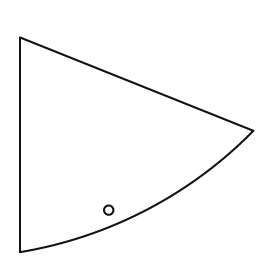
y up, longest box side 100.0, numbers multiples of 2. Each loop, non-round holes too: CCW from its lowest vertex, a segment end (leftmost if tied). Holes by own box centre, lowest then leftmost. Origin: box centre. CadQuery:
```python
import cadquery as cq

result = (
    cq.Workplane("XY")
    .moveTo(-50.0, -46.0)
    .threePointArc((4.0, -28.0), (50.0, 6.0))
    .lineTo(-50.0, 46.0)
    .close()
    .moveTo(-12.0, -28.0)
    .circle(2.0)
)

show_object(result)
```